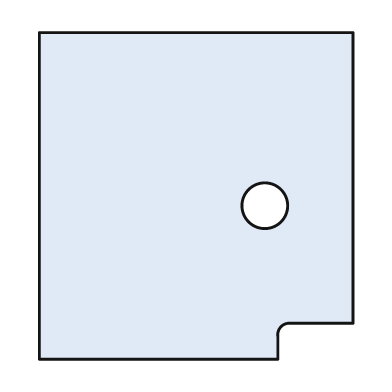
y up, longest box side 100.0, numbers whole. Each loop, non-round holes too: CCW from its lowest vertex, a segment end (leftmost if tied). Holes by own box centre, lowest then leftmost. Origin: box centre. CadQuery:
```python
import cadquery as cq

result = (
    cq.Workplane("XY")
    .moveTo(-48.0, -50.0)
    .lineTo(25.0, -50.0)
    .lineTo(25.0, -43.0)
    .threePointArc((26.0, -40.0), (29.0, -39.0))
    .lineTo(48.0, -39.0)
    .lineTo(48.0, 50.0)
    .lineTo(-48.0, 50.0)
    .close()
    .moveTo(21.0, -3.0)
    .circle(7.0)
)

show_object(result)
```